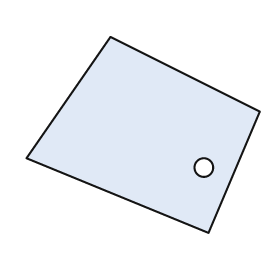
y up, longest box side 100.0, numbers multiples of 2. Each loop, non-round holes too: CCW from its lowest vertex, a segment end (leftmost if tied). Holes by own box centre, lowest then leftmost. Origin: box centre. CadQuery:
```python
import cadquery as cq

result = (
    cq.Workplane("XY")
    .moveTo(28.0, -42.0)
    .lineTo(50.0, 10.0)
    .lineTo(-14.0, 42.0)
    .lineTo(-50.0, -10.0)
    .close()
    .moveTo(26.0, -14.0)
    .circle(4.0)
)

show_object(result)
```